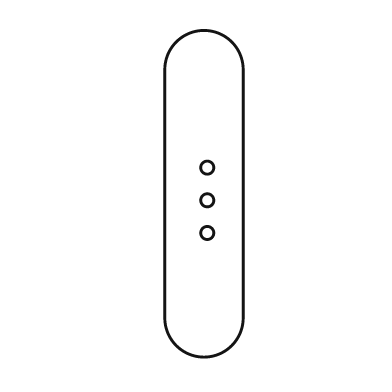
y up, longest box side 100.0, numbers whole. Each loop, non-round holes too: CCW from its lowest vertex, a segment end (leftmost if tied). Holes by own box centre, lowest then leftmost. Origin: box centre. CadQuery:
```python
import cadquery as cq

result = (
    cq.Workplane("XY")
    .moveTo(-12.0, -38.0)
    .threePointArc((0.0, -50.0), (12.0, -38.0))
    .lineTo(12.0, 38.0)
    .threePointArc((0.0, 50.0), (-12.0, 38.0))
    .close()
    .moveTo(1.0, -12.0)
    .circle(2.0)
    .moveTo(1.0, -2.0)
    .circle(2.0)
    .moveTo(1.0, 8.0)
    .circle(2.0)
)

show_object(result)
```